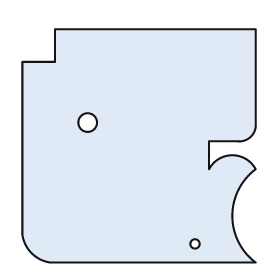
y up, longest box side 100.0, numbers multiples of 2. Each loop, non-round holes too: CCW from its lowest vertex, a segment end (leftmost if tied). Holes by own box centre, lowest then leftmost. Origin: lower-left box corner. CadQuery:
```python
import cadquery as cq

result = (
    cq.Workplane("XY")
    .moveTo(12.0, 0.0)
    .lineTo(100.0, 0.0)
    .threePointArc((90.0, 20.0), (100.0, 40.0))
    .threePointArc((90.0, 46.0), (80.0, 40.0))
    .lineTo(80.0, 52.0)
    .lineTo(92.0, 52.0)
    .threePointArc((98.0, 54.0), (100.0, 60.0))
    .lineTo(100.0, 100.0)
    .lineTo(14.0, 100.0)
    .lineTo(14.0, 86.0)
    .lineTo(0.0, 86.0)
    .lineTo(0.0, 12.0)
    .threePointArc((4.0, 4.0), (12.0, 0.0))
    .close()
    .moveTo(74.0, 8.0)
    .circle(2.0)
    .moveTo(28.0, 60.0)
    .circle(4.0)
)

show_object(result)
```